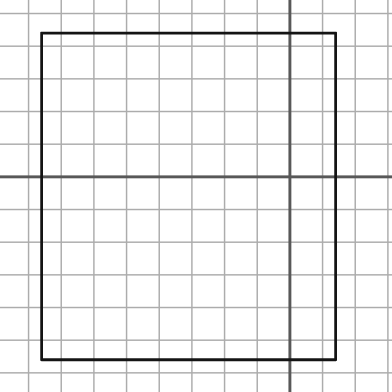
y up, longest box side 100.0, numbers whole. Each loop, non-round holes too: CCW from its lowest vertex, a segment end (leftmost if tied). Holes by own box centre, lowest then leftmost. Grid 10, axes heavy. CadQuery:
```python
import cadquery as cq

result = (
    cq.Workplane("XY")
    .moveTo(-76.0, -56.0)
    .lineTo(14.0, -56.0)
    .lineTo(14.0, 44.0)
    .lineTo(-76.0, 44.0)
    .close()
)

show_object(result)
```